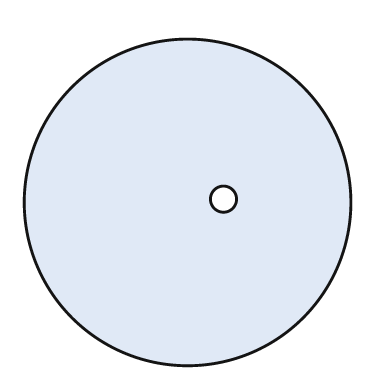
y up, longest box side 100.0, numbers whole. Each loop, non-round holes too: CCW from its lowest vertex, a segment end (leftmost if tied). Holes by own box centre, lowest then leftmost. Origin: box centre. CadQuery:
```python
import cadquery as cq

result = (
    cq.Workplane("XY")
    .moveTo(0.0, 0.0)
    .circle(50.0)
    .moveTo(11.0, 1.0)
    .circle(4.0)
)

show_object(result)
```